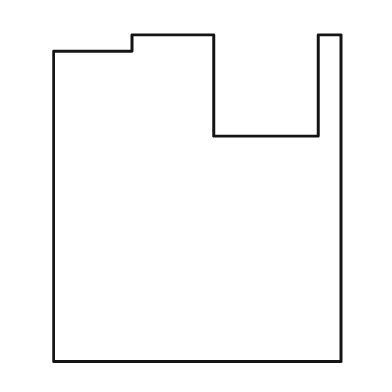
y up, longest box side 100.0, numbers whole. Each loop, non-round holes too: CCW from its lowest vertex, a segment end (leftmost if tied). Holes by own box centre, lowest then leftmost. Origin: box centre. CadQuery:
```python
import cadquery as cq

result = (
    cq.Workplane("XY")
    .moveTo(-44.0, -50.0)
    .lineTo(44.0, -50.0)
    .lineTo(44.0, 50.0)
    .lineTo(37.0, 50.0)
    .lineTo(37.0, 19.0)
    .lineTo(5.0, 19.0)
    .lineTo(5.0, 50.0)
    .lineTo(-20.0, 50.0)
    .lineTo(-20.0, 45.0)
    .lineTo(-44.0, 45.0)
    .close()
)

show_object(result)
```